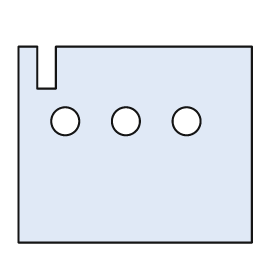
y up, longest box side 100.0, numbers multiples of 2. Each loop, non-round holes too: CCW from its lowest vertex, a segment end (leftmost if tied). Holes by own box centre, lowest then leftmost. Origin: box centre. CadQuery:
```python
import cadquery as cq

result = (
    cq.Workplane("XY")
    .moveTo(-50.0, -42.0)
    .lineTo(50.0, -42.0)
    .lineTo(50.0, 42.0)
    .lineTo(-34.0, 42.0)
    .lineTo(-34.0, 24.0)
    .lineTo(-42.0, 24.0)
    .lineTo(-42.0, 42.0)
    .lineTo(-50.0, 42.0)
    .close()
    .moveTo(-30.0, 10.0)
    .circle(6.0)
    .moveTo(-4.0, 10.0)
    .circle(6.0)
    .moveTo(22.0, 10.0)
    .circle(6.0)
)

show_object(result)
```